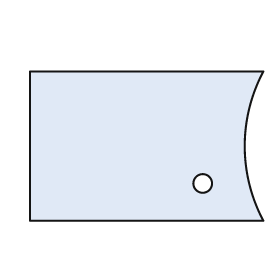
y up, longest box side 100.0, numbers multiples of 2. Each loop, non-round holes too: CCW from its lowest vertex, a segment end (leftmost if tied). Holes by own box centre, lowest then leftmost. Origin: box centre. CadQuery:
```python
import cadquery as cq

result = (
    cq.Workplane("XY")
    .moveTo(-50.0, -32.0)
    .lineTo(50.0, -32.0)
    .threePointArc((42.0, 0.0), (50.0, 32.0))
    .lineTo(-50.0, 32.0)
    .close()
    .moveTo(24.0, -16.0)
    .circle(4.0)
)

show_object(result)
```